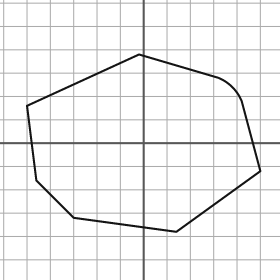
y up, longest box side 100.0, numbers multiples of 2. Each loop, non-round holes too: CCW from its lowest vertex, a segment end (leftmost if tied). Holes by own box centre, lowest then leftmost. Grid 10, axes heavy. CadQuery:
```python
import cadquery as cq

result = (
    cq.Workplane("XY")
    .moveTo(14.0, -38.0)
    .lineTo(50.0, -12.0)
    .lineTo(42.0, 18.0)
    .threePointArc((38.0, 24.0), (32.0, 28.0))
    .lineTo(-2.0, 38.0)
    .lineTo(-50.0, 16.0)
    .lineTo(-46.0, -16.0)
    .lineTo(-30.0, -32.0)
    .close()
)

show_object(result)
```